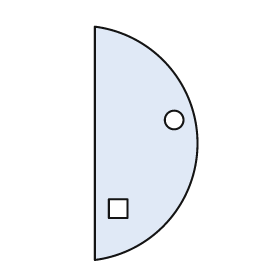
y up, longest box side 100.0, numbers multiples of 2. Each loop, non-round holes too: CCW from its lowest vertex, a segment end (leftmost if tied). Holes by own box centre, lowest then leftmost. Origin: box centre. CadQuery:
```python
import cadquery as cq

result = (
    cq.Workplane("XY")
    .moveTo(-22.0, -50.0)
    .threePointArc((22.0, 0.0), (-22.0, 50.0))
    .close()
    .moveTo(-16.0, -32.0)
    .lineTo(-8.0, -32.0)
    .lineTo(-8.0, -24.0)
    .lineTo(-16.0, -24.0)
    .close()
    .moveTo(12.0, 10.0)
    .circle(4.0)
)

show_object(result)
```